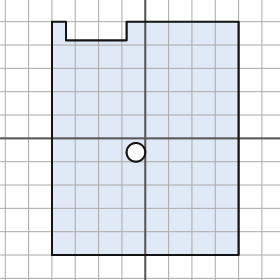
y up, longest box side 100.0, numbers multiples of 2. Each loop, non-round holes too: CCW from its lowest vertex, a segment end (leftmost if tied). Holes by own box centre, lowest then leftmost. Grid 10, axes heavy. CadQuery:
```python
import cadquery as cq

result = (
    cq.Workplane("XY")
    .moveTo(-40.0, -50.0)
    .lineTo(40.0, -50.0)
    .lineTo(40.0, 50.0)
    .lineTo(-8.0, 50.0)
    .lineTo(-8.0, 42.0)
    .lineTo(-34.0, 42.0)
    .lineTo(-34.0, 50.0)
    .lineTo(-40.0, 50.0)
    .close()
    .moveTo(-4.0, -6.0)
    .circle(4.0)
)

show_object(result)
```